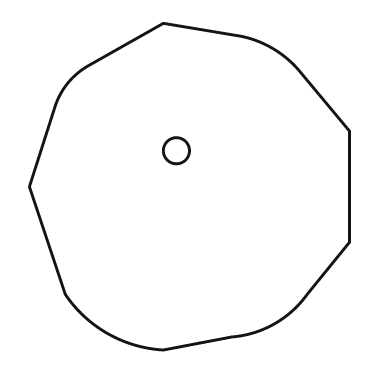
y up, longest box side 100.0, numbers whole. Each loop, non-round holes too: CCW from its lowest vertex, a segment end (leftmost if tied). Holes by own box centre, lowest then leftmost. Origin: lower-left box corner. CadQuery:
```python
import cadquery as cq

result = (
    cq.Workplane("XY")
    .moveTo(41.0, 0.0)
    .lineTo(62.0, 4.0)
    .threePointArc((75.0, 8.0), (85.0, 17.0))
    .lineTo(98.0, 33.0)
    .lineTo(98.0, 67.0)
    .lineTo(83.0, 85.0)
    .threePointArc((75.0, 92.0), (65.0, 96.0))
    .lineTo(41.0, 100.0)
    .lineTo(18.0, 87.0)
    .threePointArc((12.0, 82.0), (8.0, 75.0))
    .lineTo(0.0, 50.0)
    .lineTo(11.0, 17.0)
    .threePointArc((24.0, 5.0), (41.0, 0.0))
    .close()
    .moveTo(45.0, 61.0)
    .circle(4.0)
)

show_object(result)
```